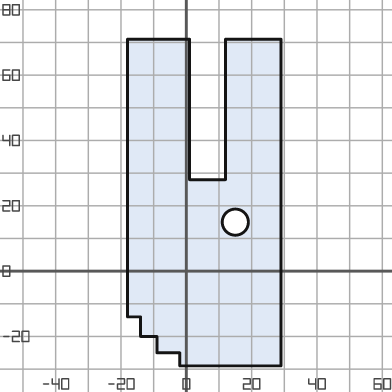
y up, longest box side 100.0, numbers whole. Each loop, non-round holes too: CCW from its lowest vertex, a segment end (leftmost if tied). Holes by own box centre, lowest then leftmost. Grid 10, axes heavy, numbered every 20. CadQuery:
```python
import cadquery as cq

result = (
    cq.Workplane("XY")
    .moveTo(-2.0, -29.0)
    .lineTo(29.0, -29.0)
    .lineTo(29.0, 71.0)
    .lineTo(12.0, 71.0)
    .lineTo(12.0, 28.0)
    .lineTo(1.0, 28.0)
    .lineTo(1.0, 71.0)
    .lineTo(-18.0, 71.0)
    .lineTo(-18.0, -14.0)
    .lineTo(-14.0, -14.0)
    .lineTo(-14.0, -20.0)
    .lineTo(-9.0, -20.0)
    .lineTo(-9.0, -25.0)
    .lineTo(-2.0, -25.0)
    .close()
    .moveTo(15.0, 15.0)
    .circle(4.0)
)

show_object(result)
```